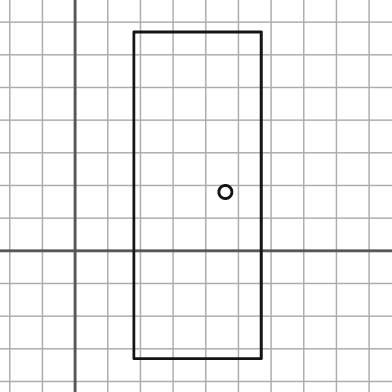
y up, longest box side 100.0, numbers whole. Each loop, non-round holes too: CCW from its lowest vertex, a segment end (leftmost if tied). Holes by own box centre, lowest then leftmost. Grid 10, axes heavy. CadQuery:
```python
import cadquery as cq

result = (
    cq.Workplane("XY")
    .moveTo(18.0, -33.0)
    .lineTo(57.0, -33.0)
    .lineTo(57.0, 67.0)
    .lineTo(18.0, 67.0)
    .close()
    .moveTo(46.0, 18.0)
    .circle(2.0)
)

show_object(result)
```